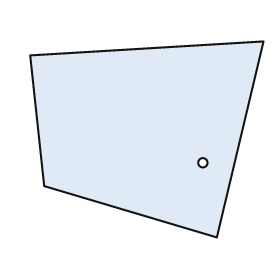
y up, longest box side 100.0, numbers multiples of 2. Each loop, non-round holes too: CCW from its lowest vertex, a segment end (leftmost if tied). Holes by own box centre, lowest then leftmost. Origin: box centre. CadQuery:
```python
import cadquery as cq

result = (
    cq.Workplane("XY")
    .moveTo(30.0, -42.0)
    .lineTo(50.0, 42.0)
    .lineTo(-50.0, 36.0)
    .lineTo(-44.0, -20.0)
    .close()
    .moveTo(24.0, -10.0)
    .circle(2.0)
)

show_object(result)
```